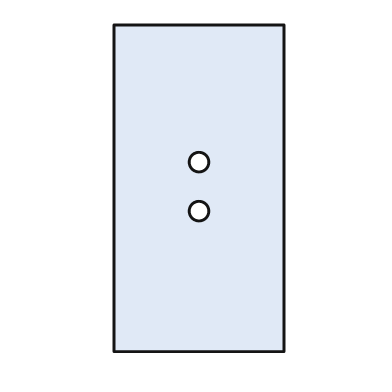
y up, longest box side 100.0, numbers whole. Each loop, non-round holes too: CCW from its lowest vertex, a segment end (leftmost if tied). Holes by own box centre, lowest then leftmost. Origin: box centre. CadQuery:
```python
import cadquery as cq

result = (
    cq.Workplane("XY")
    .moveTo(-26.0, -50.0)
    .lineTo(26.0, -50.0)
    .lineTo(26.0, 50.0)
    .lineTo(-26.0, 50.0)
    .close()
    .moveTo(0.0, -7.0)
    .circle(3.0)
    .moveTo(0.0, 8.0)
    .circle(3.0)
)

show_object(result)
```